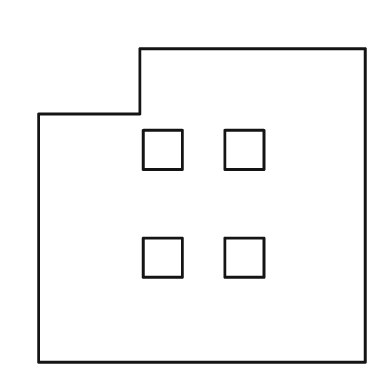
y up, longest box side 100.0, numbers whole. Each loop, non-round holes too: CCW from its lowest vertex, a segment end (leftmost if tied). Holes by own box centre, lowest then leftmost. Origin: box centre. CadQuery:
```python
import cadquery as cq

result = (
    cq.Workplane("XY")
    .moveTo(-50.0, -48.0)
    .lineTo(50.0, -48.0)
    .lineTo(50.0, 48.0)
    .lineTo(-19.0, 48.0)
    .lineTo(-19.0, 28.0)
    .lineTo(-50.0, 28.0)
    .close()
    .moveTo(-18.0, -22.0)
    .lineTo(-6.0, -22.0)
    .lineTo(-6.0, -10.0)
    .lineTo(-18.0, -10.0)
    .close()
    .moveTo(7.0, -22.0)
    .lineTo(19.0, -22.0)
    .lineTo(19.0, -10.0)
    .lineTo(7.0, -10.0)
    .close()
    .moveTo(-18.0, 11.0)
    .lineTo(-6.0, 11.0)
    .lineTo(-6.0, 23.0)
    .lineTo(-18.0, 23.0)
    .close()
    .moveTo(7.0, 11.0)
    .lineTo(19.0, 11.0)
    .lineTo(19.0, 23.0)
    .lineTo(7.0, 23.0)
    .close()
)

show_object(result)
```